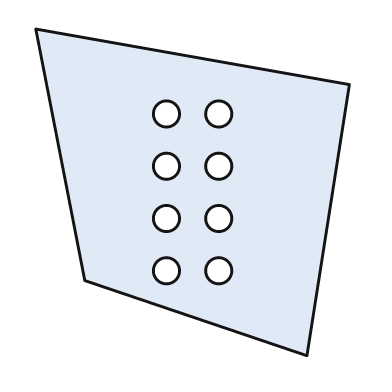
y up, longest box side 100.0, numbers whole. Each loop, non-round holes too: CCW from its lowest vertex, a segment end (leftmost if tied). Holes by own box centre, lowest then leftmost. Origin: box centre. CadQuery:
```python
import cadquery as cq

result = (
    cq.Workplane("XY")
    .moveTo(35.0, -50.0)
    .lineTo(48.0, 33.0)
    .lineTo(-48.0, 50.0)
    .lineTo(-33.0, -27.0)
    .close()
    .moveTo(-8.0, -24.0)
    .circle(4.0)
    .moveTo(8.0, -24.0)
    .circle(4.0)
    .moveTo(-8.0, -8.0)
    .circle(4.0)
    .moveTo(8.0, -8.0)
    .circle(4.0)
    .moveTo(-8.0, 8.0)
    .circle(4.0)
    .moveTo(8.0, 8.0)
    .circle(4.0)
    .moveTo(-8.0, 24.0)
    .circle(4.0)
    .moveTo(8.0, 24.0)
    .circle(4.0)
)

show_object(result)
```